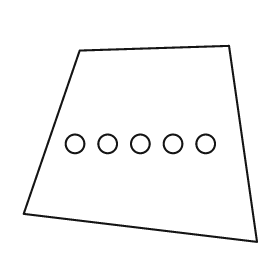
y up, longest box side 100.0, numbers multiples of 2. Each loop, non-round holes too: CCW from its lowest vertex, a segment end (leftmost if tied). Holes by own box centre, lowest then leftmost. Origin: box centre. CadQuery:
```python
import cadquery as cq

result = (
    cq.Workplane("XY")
    .moveTo(50.0, -42.0)
    .lineTo(38.0, 42.0)
    .lineTo(-26.0, 40.0)
    .lineTo(-50.0, -30.0)
    .close()
    .moveTo(-28.0, 0.0)
    .circle(4.0)
    .moveTo(-14.0, 0.0)
    .circle(4.0)
    .moveTo(0.0, 0.0)
    .circle(4.0)
    .moveTo(14.0, 0.0)
    .circle(4.0)
    .moveTo(28.0, 0.0)
    .circle(4.0)
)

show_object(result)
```